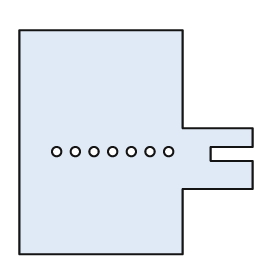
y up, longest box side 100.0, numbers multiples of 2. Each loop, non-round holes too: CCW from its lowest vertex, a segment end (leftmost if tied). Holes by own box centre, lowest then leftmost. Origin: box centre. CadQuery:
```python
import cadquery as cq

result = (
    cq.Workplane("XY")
    .moveTo(-50.0, -48.0)
    .lineTo(20.0, -48.0)
    .lineTo(20.0, -20.0)
    .lineTo(50.0, -20.0)
    .lineTo(50.0, -8.0)
    .lineTo(32.0, -8.0)
    .lineTo(32.0, -2.0)
    .lineTo(50.0, -2.0)
    .lineTo(50.0, 6.0)
    .lineTo(20.0, 6.0)
    .lineTo(20.0, 48.0)
    .lineTo(-50.0, 48.0)
    .close()
    .moveTo(-34.0, -4.0)
    .circle(2.0)
    .moveTo(-26.0, -4.0)
    .circle(2.0)
    .moveTo(-18.0, -4.0)
    .circle(2.0)
    .moveTo(-10.0, -4.0)
    .circle(2.0)
    .moveTo(-2.0, -4.0)
    .circle(2.0)
    .moveTo(6.0, -4.0)
    .circle(2.0)
    .moveTo(14.0, -4.0)
    .circle(2.0)
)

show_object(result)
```